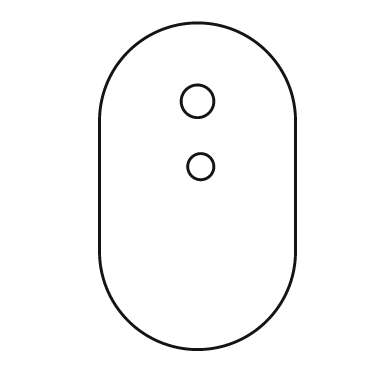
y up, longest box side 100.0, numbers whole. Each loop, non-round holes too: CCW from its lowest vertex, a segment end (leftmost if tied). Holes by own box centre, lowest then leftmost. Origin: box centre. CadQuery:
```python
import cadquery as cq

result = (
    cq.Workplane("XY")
    .moveTo(-30.0, -20.0)
    .threePointArc((0.0, -50.0), (30.0, -20.0))
    .lineTo(30.0, 20.0)
    .threePointArc((0.0, 50.0), (-30.0, 20.0))
    .close()
    .moveTo(1.0, 6.0)
    .circle(4.0)
    .moveTo(0.0, 26.0)
    .circle(5.0)
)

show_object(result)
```